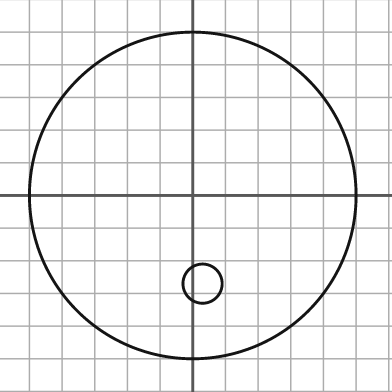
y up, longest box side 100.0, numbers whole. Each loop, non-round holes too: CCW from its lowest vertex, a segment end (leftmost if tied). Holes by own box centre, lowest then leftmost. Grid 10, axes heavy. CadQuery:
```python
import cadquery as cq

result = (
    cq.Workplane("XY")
    .moveTo(0.0, 0.0)
    .circle(50.0)
    .moveTo(3.0, -27.0)
    .circle(6.0)
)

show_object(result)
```